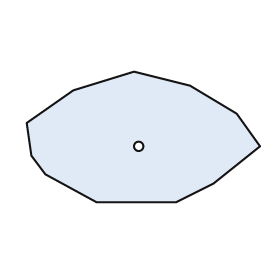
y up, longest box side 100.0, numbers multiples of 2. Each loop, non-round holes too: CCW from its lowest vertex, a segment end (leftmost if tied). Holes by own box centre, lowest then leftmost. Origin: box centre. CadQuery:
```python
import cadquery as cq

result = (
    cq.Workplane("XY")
    .moveTo(-20.0, -28.0)
    .lineTo(14.0, -28.0)
    .lineTo(30.0, -20.0)
    .lineTo(50.0, -4.0)
    .lineTo(40.0, 10.0)
    .lineTo(20.0, 22.0)
    .lineTo(-4.0, 28.0)
    .lineTo(-30.0, 20.0)
    .lineTo(-50.0, 6.0)
    .lineTo(-48.0, -8.0)
    .lineTo(-42.0, -16.0)
    .close()
    .moveTo(-2.0, -4.0)
    .circle(2.0)
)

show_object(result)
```